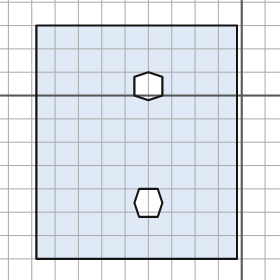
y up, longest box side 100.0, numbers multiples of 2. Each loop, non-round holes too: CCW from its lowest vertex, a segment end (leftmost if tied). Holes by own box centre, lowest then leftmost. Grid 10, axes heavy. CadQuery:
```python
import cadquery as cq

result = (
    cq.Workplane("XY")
    .moveTo(-88.0, -70.0)
    .lineTo(-2.0, -70.0)
    .lineTo(-2.0, 30.0)
    .lineTo(-88.0, 30.0)
    .close()
    .moveTo(-44.0, -52.0)
    .lineTo(-36.0, -52.0)
    .lineTo(-34.0, -46.0)
    .lineTo(-36.0, -40.0)
    .lineTo(-44.0, -40.0)
    .lineTo(-46.0, -46.0)
    .close()
    .moveTo(-40.0, -2.0)
    .lineTo(-34.0, 0.0)
    .lineTo(-34.0, 8.0)
    .lineTo(-40.0, 10.0)
    .lineTo(-46.0, 8.0)
    .lineTo(-46.0, 0.0)
    .close()
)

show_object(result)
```